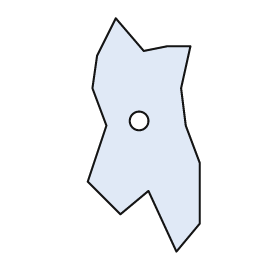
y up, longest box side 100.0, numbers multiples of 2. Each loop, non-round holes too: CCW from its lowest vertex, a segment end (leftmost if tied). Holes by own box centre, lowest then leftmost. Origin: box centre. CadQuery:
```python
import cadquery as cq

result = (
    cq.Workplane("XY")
    .moveTo(14.0, -50.0)
    .lineTo(24.0, -38.0)
    .lineTo(24.0, -12.0)
    .lineTo(18.0, 4.0)
    .lineTo(16.0, 20.0)
    .lineTo(20.0, 38.0)
    .lineTo(10.0, 38.0)
    .lineTo(0.0, 36.0)
    .lineTo(-12.0, 50.0)
    .lineTo(-20.0, 34.0)
    .lineTo(-22.0, 20.0)
    .lineTo(-16.0, 4.0)
    .lineTo(-24.0, -20.0)
    .lineTo(-10.0, -34.0)
    .lineTo(2.0, -24.0)
    .close()
    .moveTo(-2.0, 6.0)
    .circle(4.0)
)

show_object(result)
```